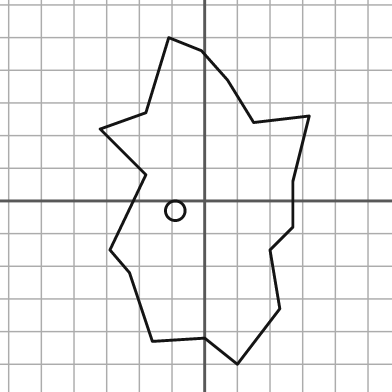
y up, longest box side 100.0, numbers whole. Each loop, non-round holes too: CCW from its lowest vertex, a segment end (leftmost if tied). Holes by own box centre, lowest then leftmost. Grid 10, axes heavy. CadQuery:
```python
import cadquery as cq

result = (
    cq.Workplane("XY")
    .moveTo(10.0, -50.0)
    .lineTo(23.0, -33.0)
    .lineTo(20.0, -15.0)
    .lineTo(27.0, -8.0)
    .lineTo(27.0, 6.0)
    .lineTo(32.0, 26.0)
    .lineTo(15.0, 24.0)
    .lineTo(7.0, 37.0)
    .lineTo(-1.0, 46.0)
    .lineTo(-11.0, 50.0)
    .lineTo(-18.0, 27.0)
    .lineTo(-32.0, 22.0)
    .lineTo(-18.0, 8.0)
    .lineTo(-29.0, -15.0)
    .lineTo(-23.0, -22.0)
    .lineTo(-16.0, -43.0)
    .lineTo(0.0, -42.0)
    .close()
    .moveTo(-9.0, -3.0)
    .circle(3.0)
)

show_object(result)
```